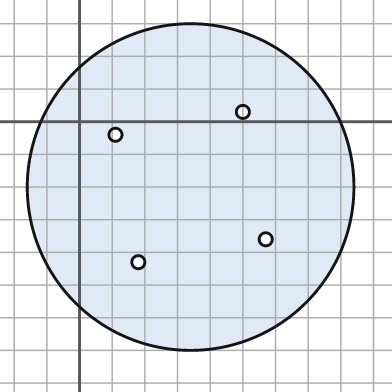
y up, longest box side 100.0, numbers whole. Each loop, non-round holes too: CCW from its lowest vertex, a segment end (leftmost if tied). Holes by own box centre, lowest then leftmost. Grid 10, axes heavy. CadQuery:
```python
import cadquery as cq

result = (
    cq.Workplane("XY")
    .moveTo(34.0, -20.0)
    .circle(50.0)
    .moveTo(18.0, -43.0)
    .circle(2.0)
    .moveTo(57.0, -36.0)
    .circle(2.0)
    .moveTo(11.0, -4.0)
    .circle(2.0)
    .moveTo(50.0, 3.0)
    .circle(2.0)
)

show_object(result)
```